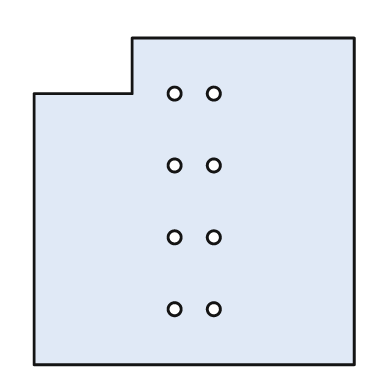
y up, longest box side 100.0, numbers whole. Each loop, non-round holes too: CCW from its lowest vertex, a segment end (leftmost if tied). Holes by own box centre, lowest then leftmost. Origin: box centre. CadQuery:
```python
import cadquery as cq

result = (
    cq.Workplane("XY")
    .moveTo(-49.0, -50.0)
    .lineTo(49.0, -50.0)
    .lineTo(49.0, 50.0)
    .lineTo(-19.0, 50.0)
    .lineTo(-19.0, 33.0)
    .lineTo(-49.0, 33.0)
    .close()
    .moveTo(-6.0, -33.0)
    .circle(2.0)
    .moveTo(6.0, -33.0)
    .circle(2.0)
    .moveTo(-6.0, -11.0)
    .circle(2.0)
    .moveTo(6.0, -11.0)
    .circle(2.0)
    .moveTo(-6.0, 11.0)
    .circle(2.0)
    .moveTo(6.0, 11.0)
    .circle(2.0)
    .moveTo(-6.0, 33.0)
    .circle(2.0)
    .moveTo(6.0, 33.0)
    .circle(2.0)
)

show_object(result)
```